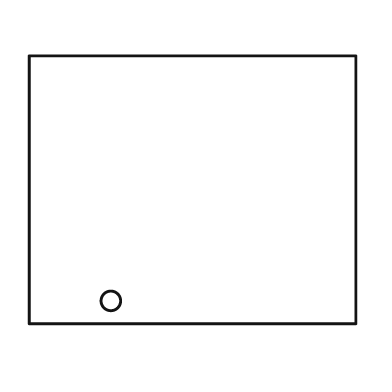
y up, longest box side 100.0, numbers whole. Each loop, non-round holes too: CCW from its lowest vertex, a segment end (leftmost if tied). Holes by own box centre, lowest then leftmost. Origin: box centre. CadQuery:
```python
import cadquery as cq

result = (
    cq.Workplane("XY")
    .moveTo(-50.0, -41.0)
    .lineTo(50.0, -41.0)
    .lineTo(50.0, 41.0)
    .lineTo(-50.0, 41.0)
    .close()
    .moveTo(-25.0, -34.0)
    .circle(3.0)
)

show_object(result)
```